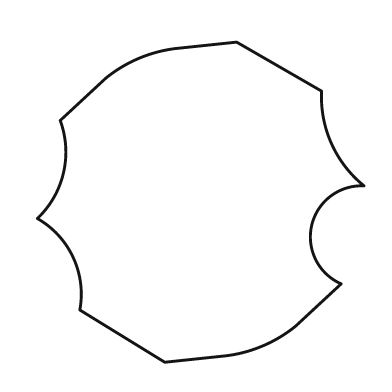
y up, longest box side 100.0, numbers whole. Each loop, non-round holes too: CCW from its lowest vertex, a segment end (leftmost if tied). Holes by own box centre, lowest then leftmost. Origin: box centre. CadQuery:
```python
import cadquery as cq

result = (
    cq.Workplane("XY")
    .moveTo(-11.0, -49.0)
    .lineTo(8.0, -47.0)
    .threePointArc((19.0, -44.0), (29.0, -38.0))
    .lineTo(43.0, -25.0)
    .threePointArc((34.0, -7.0), (50.0, 5.0))
    .threePointArc((40.0, 18.0), (37.0, 34.0))
    .lineTo(11.0, 49.0)
    .lineTo(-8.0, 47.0)
    .threePointArc((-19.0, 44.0), (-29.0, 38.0))
    .lineTo(-43.0, 25.0)
    .threePointArc((-42.0, 9.0), (-50.0, -5.0))
    .threePointArc((-39.0, -17.0), (-37.0, -33.0))
    .close()
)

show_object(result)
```